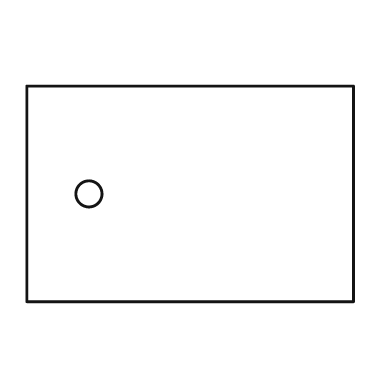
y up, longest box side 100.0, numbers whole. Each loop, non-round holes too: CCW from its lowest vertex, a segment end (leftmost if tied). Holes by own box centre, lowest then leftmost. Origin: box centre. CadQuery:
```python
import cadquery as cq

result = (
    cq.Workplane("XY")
    .moveTo(-50.0, -33.0)
    .lineTo(50.0, -33.0)
    .lineTo(50.0, 33.0)
    .lineTo(-50.0, 33.0)
    .close()
    .moveTo(-31.0, 0.0)
    .circle(4.0)
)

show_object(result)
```